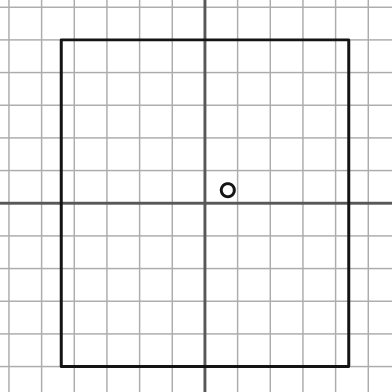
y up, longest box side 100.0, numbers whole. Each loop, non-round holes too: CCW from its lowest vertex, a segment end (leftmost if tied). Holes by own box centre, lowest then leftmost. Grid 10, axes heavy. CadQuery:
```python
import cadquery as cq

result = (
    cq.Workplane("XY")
    .moveTo(-44.0, -50.0)
    .lineTo(44.0, -50.0)
    .lineTo(44.0, 50.0)
    .lineTo(-44.0, 50.0)
    .close()
    .moveTo(7.0, 4.0)
    .circle(2.0)
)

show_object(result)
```